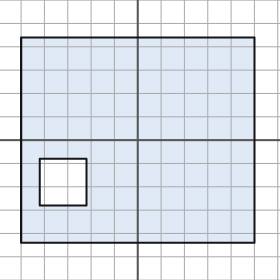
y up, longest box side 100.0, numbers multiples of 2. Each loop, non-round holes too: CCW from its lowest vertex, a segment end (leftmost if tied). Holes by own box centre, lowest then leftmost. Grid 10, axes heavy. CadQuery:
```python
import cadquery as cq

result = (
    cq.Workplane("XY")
    .moveTo(-50.0, -44.0)
    .lineTo(50.0, -44.0)
    .lineTo(50.0, 44.0)
    .lineTo(-50.0, 44.0)
    .close()
    .moveTo(-42.0, -28.0)
    .lineTo(-22.0, -28.0)
    .lineTo(-22.0, -8.0)
    .lineTo(-42.0, -8.0)
    .close()
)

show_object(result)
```